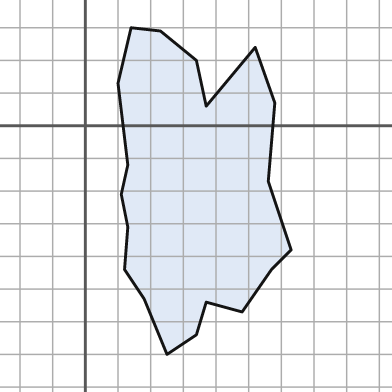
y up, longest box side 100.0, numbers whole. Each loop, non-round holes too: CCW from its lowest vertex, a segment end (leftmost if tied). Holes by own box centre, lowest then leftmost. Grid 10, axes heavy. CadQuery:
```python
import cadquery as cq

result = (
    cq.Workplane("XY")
    .moveTo(25.0, -70.0)
    .lineTo(34.0, -64.0)
    .lineTo(37.0, -54.0)
    .lineTo(48.0, -57.0)
    .lineTo(57.0, -44.0)
    .lineTo(63.0, -38.0)
    .lineTo(56.0, -17.0)
    .lineTo(58.0, 7.0)
    .lineTo(52.0, 24.0)
    .lineTo(37.0, 6.0)
    .lineTo(34.0, 20.0)
    .lineTo(23.0, 29.0)
    .lineTo(14.0, 30.0)
    .lineTo(10.0, 13.0)
    .lineTo(13.0, -12.0)
    .lineTo(11.0, -21.0)
    .lineTo(13.0, -31.0)
    .lineTo(12.0, -44.0)
    .lineTo(18.0, -53.0)
    .close()
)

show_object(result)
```